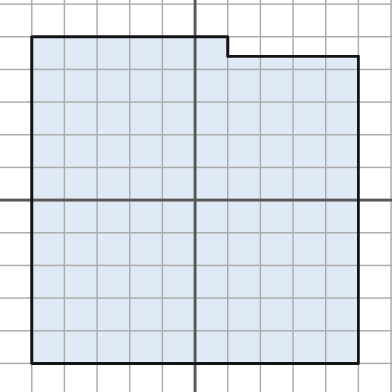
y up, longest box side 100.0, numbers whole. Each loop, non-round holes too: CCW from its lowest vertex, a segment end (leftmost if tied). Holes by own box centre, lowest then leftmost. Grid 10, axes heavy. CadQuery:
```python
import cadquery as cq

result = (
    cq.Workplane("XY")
    .moveTo(-50.0, -50.0)
    .lineTo(50.0, -50.0)
    .lineTo(50.0, 44.0)
    .lineTo(10.0, 44.0)
    .lineTo(10.0, 50.0)
    .lineTo(-50.0, 50.0)
    .close()
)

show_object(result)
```